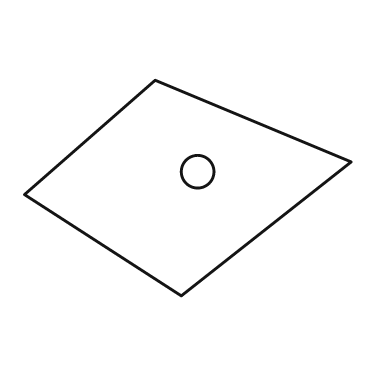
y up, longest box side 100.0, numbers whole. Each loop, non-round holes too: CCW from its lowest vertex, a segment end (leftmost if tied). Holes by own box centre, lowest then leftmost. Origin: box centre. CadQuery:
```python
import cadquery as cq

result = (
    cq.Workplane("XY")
    .moveTo(-2.0, -33.0)
    .lineTo(50.0, 8.0)
    .lineTo(-10.0, 33.0)
    .lineTo(-50.0, -2.0)
    .close()
    .moveTo(3.0, 5.0)
    .circle(5.0)
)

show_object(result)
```